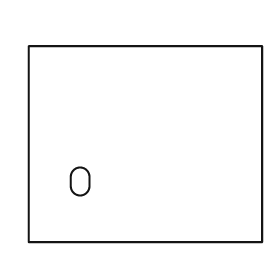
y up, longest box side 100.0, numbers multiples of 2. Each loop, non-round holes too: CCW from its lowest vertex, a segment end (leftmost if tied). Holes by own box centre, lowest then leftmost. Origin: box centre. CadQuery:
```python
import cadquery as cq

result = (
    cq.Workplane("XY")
    .moveTo(-50.0, -42.0)
    .lineTo(50.0, -42.0)
    .lineTo(50.0, 42.0)
    .lineTo(-50.0, 42.0)
    .close()
    .moveTo(-32.0, -18.0)
    .threePointArc((-28.0, -22.0), (-24.0, -18.0))
    .lineTo(-24.0, -14.0)
    .threePointArc((-28.0, -10.0), (-32.0, -14.0))
    .close()
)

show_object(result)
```